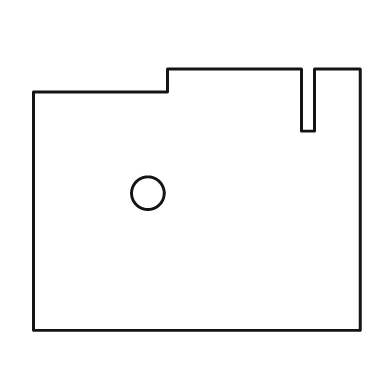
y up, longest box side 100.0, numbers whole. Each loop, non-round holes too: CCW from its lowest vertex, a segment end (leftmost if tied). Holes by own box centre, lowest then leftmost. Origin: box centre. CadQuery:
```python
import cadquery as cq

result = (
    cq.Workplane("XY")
    .moveTo(-50.0, -40.0)
    .lineTo(50.0, -40.0)
    .lineTo(50.0, 40.0)
    .lineTo(36.0, 40.0)
    .lineTo(36.0, 21.0)
    .lineTo(32.0, 21.0)
    .lineTo(32.0, 40.0)
    .lineTo(-9.0, 40.0)
    .lineTo(-9.0, 33.0)
    .lineTo(-50.0, 33.0)
    .close()
    .moveTo(-15.0, 2.0)
    .circle(5.0)
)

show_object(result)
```